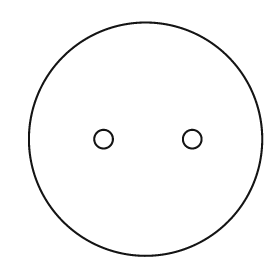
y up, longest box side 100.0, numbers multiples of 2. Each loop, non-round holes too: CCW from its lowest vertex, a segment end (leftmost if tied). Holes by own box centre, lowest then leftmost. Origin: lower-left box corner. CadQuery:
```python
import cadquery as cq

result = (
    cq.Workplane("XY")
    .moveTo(50.0, 50.0)
    .circle(50.0)
    .moveTo(32.0, 50.0)
    .circle(4.0)
    .moveTo(70.0, 50.0)
    .circle(4.0)
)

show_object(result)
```